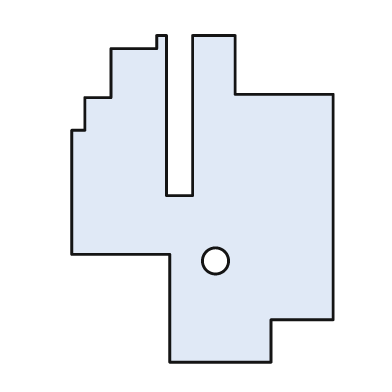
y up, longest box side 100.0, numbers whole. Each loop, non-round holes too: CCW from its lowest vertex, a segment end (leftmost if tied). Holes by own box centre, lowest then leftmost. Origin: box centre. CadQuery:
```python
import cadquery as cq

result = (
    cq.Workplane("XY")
    .moveTo(-10.0, -50.0)
    .lineTo(21.0, -50.0)
    .lineTo(21.0, -37.0)
    .lineTo(40.0, -37.0)
    .lineTo(40.0, 32.0)
    .lineTo(10.0, 32.0)
    .lineTo(10.0, 50.0)
    .lineTo(-3.0, 50.0)
    .lineTo(-3.0, 1.0)
    .lineTo(-11.0, 1.0)
    .lineTo(-11.0, 50.0)
    .lineTo(-14.0, 50.0)
    .lineTo(-14.0, 46.0)
    .lineTo(-28.0, 46.0)
    .lineTo(-28.0, 31.0)
    .lineTo(-36.0, 31.0)
    .lineTo(-36.0, 21.0)
    .lineTo(-40.0, 21.0)
    .lineTo(-40.0, -17.0)
    .lineTo(-10.0, -17.0)
    .close()
    .moveTo(4.0, -19.0)
    .circle(4.0)
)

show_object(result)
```